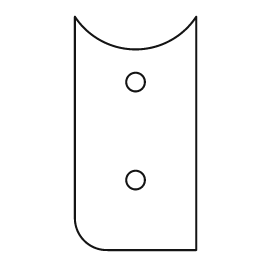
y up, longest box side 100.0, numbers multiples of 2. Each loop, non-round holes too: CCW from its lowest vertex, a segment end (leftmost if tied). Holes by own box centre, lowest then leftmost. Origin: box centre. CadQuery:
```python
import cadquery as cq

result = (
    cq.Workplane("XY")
    .moveTo(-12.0, -50.0)
    .lineTo(26.0, -50.0)
    .lineTo(26.0, 50.0)
    .threePointArc((0.0, 36.0), (-26.0, 50.0))
    .lineTo(-26.0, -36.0)
    .threePointArc((-22.0, -46.0), (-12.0, -50.0))
    .close()
    .moveTo(0.0, -20.0)
    .circle(4.0)
    .moveTo(0.0, 22.0)
    .circle(4.0)
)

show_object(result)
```